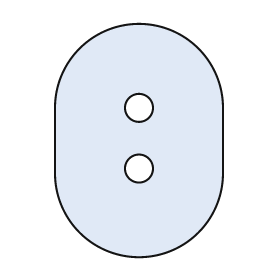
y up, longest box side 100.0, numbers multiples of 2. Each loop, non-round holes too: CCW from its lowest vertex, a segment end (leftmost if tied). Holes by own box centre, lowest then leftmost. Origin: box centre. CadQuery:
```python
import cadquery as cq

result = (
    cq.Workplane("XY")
    .moveTo(-36.0, -14.0)
    .threePointArc((0.0, -50.0), (36.0, -14.0))
    .lineTo(36.0, 14.0)
    .threePointArc((0.0, 50.0), (-36.0, 14.0))
    .close()
    .moveTo(0.0, -12.0)
    .circle(6.0)
    .moveTo(0.0, 14.0)
    .circle(6.0)
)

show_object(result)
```